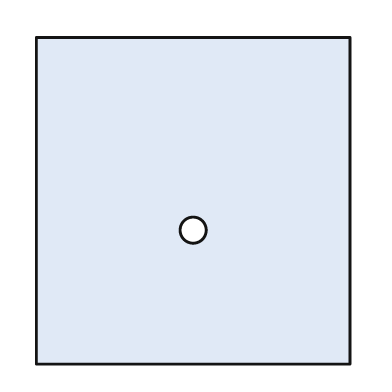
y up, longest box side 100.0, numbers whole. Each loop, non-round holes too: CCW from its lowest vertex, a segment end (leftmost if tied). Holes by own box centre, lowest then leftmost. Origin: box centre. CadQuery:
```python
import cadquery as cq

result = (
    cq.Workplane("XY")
    .moveTo(-48.0, -50.0)
    .lineTo(48.0, -50.0)
    .lineTo(48.0, 50.0)
    .lineTo(-48.0, 50.0)
    .close()
    .moveTo(0.0, -9.0)
    .circle(4.0)
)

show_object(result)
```